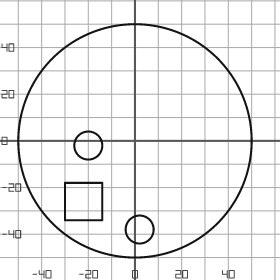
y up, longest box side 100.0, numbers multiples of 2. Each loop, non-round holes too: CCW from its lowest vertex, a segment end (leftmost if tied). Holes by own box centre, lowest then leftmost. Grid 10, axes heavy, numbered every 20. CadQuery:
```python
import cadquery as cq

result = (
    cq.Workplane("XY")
    .moveTo(0.0, 0.0)
    .circle(50.0)
    .moveTo(2.0, -38.0)
    .circle(6.0)
    .moveTo(-30.0, -34.0)
    .lineTo(-14.0, -34.0)
    .lineTo(-14.0, -18.0)
    .lineTo(-30.0, -18.0)
    .close()
    .moveTo(-20.0, -2.0)
    .circle(6.0)
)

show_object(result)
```